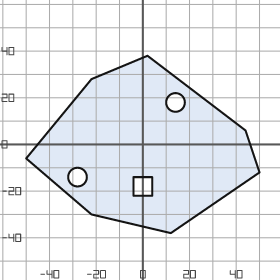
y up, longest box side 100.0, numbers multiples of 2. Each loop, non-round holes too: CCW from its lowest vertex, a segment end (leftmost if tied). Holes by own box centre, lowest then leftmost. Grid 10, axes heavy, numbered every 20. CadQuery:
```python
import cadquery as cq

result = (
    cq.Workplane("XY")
    .moveTo(12.0, -38.0)
    .lineTo(50.0, -12.0)
    .lineTo(44.0, 6.0)
    .lineTo(2.0, 38.0)
    .lineTo(-22.0, 28.0)
    .lineTo(-50.0, -6.0)
    .lineTo(-22.0, -30.0)
    .close()
    .moveTo(-4.0, -22.0)
    .lineTo(4.0, -22.0)
    .lineTo(4.0, -14.0)
    .lineTo(-4.0, -14.0)
    .close()
    .moveTo(-28.0, -14.0)
    .circle(4.0)
    .moveTo(14.0, 18.0)
    .circle(4.0)
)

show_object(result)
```